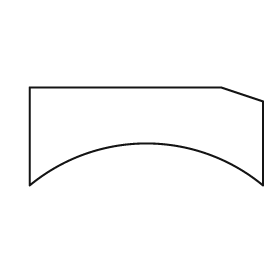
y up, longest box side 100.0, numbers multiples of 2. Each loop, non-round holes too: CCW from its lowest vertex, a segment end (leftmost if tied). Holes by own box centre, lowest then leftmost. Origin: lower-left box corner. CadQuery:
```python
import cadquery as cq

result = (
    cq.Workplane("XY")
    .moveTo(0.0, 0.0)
    .threePointArc((50.0, 18.0), (100.0, 0.0))
    .lineTo(100.0, 36.0)
    .lineTo(82.0, 42.0)
    .lineTo(0.0, 42.0)
    .close()
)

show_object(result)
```